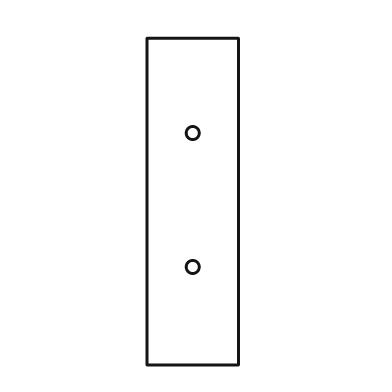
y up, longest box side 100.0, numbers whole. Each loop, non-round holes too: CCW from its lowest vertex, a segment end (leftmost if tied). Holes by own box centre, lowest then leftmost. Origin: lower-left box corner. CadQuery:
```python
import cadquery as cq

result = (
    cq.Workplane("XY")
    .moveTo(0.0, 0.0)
    .lineTo(28.0, 0.0)
    .lineTo(28.0, 100.0)
    .lineTo(0.0, 100.0)
    .close()
    .moveTo(14.0, 30.0)
    .circle(2.0)
    .moveTo(14.0, 71.0)
    .circle(2.0)
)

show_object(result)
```